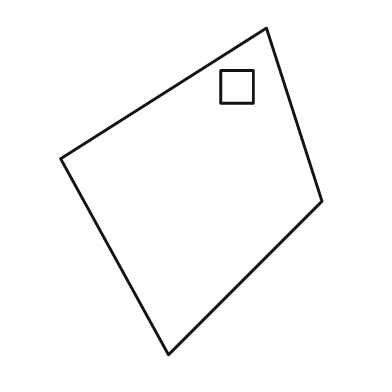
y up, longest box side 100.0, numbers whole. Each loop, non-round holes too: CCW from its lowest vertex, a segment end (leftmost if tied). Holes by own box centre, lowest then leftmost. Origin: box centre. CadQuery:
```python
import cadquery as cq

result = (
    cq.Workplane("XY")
    .moveTo(-7.0, -50.0)
    .lineTo(40.0, -3.0)
    .lineTo(23.0, 50.0)
    .lineTo(-40.0, 10.0)
    .close()
    .moveTo(9.0, 27.0)
    .lineTo(19.0, 27.0)
    .lineTo(19.0, 37.0)
    .lineTo(9.0, 37.0)
    .close()
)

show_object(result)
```